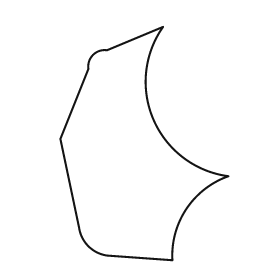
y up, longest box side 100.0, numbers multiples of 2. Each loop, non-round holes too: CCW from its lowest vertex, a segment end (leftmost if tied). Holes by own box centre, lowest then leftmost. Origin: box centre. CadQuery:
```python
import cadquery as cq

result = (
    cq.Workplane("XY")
    .moveTo(12.0, -50.0)
    .threePointArc((18.0, -28.0), (36.0, -14.0))
    .threePointArc((4.0, 10.0), (8.0, 50.0))
    .lineTo(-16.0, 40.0)
    .threePointArc((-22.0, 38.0), (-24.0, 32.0))
    .lineTo(-36.0, 2.0)
    .lineTo(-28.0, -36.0)
    .threePointArc((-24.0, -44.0), (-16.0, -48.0))
    .close()
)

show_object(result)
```